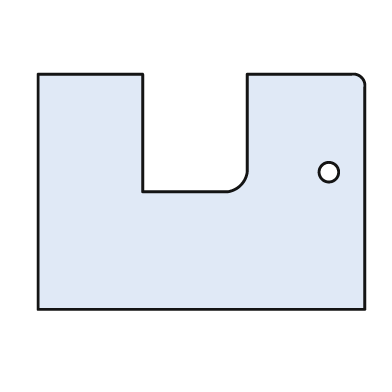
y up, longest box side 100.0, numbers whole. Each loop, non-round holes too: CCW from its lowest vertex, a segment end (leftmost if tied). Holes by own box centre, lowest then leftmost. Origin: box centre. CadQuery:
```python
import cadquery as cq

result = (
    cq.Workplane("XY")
    .moveTo(-50.0, -36.0)
    .lineTo(50.0, -36.0)
    .lineTo(50.0, 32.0)
    .threePointArc((49.0, 35.0), (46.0, 36.0))
    .lineTo(14.0, 36.0)
    .lineTo(14.0, 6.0)
    .threePointArc((12.0, 2.0), (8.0, 0.0))
    .lineTo(-18.0, 0.0)
    .lineTo(-18.0, 36.0)
    .lineTo(-50.0, 36.0)
    .close()
    .moveTo(39.0, 6.0)
    .circle(3.0)
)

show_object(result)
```